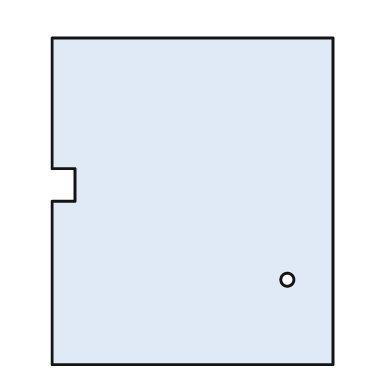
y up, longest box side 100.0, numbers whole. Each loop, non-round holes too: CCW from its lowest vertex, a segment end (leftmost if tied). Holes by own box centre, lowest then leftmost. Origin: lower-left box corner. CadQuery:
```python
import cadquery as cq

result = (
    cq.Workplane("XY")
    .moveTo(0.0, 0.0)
    .lineTo(86.0, 0.0)
    .lineTo(86.0, 100.0)
    .lineTo(0.0, 100.0)
    .lineTo(0.0, 60.0)
    .lineTo(7.0, 60.0)
    .lineTo(7.0, 50.0)
    .lineTo(0.0, 50.0)
    .close()
    .moveTo(72.0, 26.0)
    .circle(2.0)
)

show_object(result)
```